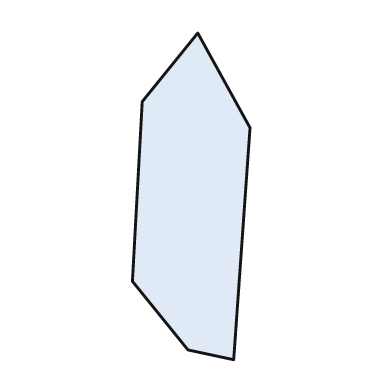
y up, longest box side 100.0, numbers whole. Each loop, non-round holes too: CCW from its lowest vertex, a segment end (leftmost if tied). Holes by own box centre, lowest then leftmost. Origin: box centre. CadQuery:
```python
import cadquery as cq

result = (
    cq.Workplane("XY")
    .moveTo(13.0, -50.0)
    .lineTo(18.0, 21.0)
    .lineTo(2.0, 50.0)
    .lineTo(-15.0, 29.0)
    .lineTo(-18.0, -26.0)
    .lineTo(-1.0, -47.0)
    .close()
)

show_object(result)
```